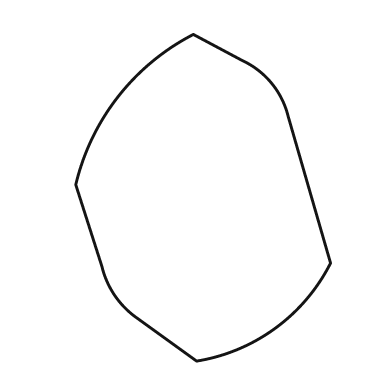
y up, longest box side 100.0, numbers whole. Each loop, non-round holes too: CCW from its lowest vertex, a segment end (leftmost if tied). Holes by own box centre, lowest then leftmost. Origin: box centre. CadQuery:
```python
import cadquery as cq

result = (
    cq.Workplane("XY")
    .moveTo(-2.0, -50.0)
    .threePointArc((22.0, -40.0), (39.0, -20.0))
    .lineTo(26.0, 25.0)
    .threePointArc((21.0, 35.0), (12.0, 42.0))
    .lineTo(-3.0, 50.0)
    .threePointArc((-26.0, 31.0), (-39.0, 4.0))
    .lineTo(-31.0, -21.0)
    .threePointArc((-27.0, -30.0), (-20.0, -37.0))
    .close()
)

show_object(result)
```